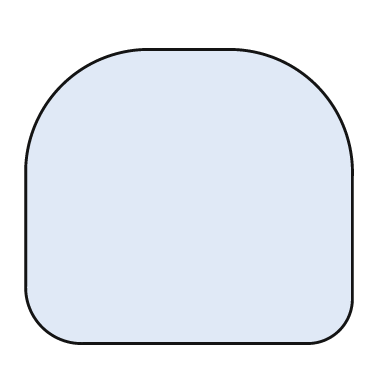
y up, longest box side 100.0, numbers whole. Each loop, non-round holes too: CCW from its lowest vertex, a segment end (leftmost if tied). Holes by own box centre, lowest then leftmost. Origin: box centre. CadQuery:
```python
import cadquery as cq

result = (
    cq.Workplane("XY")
    .moveTo(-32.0, -45.0)
    .lineTo(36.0, -45.0)
    .threePointArc((46.0, -41.0), (50.0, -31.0))
    .lineTo(50.0, 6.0)
    .threePointArc((39.0, 34.0), (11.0, 45.0))
    .lineTo(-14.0, 45.0)
    .threePointArc((-39.0, 34.0), (-50.0, 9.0))
    .lineTo(-50.0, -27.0)
    .threePointArc((-45.0, -40.0), (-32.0, -45.0))
    .close()
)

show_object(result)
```